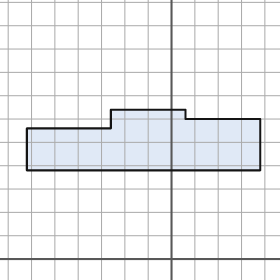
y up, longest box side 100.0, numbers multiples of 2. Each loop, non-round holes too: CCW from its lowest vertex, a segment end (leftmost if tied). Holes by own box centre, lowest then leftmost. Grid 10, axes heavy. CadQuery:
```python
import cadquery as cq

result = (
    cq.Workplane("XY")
    .moveTo(-62.0, 38.0)
    .lineTo(38.0, 38.0)
    .lineTo(38.0, 60.0)
    .lineTo(6.0, 60.0)
    .lineTo(6.0, 64.0)
    .lineTo(-26.0, 64.0)
    .lineTo(-26.0, 56.0)
    .lineTo(-62.0, 56.0)
    .close()
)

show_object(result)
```